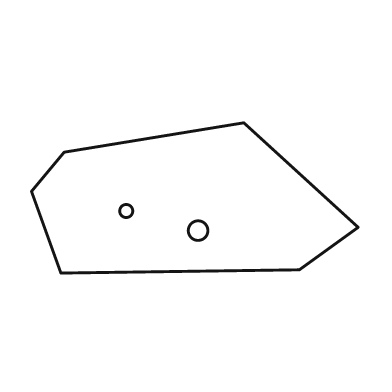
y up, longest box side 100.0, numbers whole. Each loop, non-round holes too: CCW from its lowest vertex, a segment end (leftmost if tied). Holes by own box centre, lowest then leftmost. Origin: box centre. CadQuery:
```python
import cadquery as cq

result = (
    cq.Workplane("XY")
    .moveTo(-41.0, -23.0)
    .lineTo(32.0, -22.0)
    .lineTo(50.0, -9.0)
    .lineTo(15.0, 23.0)
    .lineTo(-40.0, 14.0)
    .lineTo(-50.0, 2.0)
    .close()
    .moveTo(1.0, -10.0)
    .circle(3.0)
    .moveTo(-21.0, -4.0)
    .circle(2.0)
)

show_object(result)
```